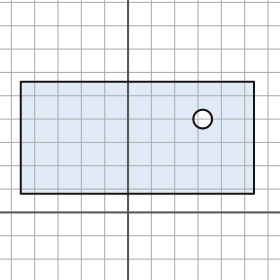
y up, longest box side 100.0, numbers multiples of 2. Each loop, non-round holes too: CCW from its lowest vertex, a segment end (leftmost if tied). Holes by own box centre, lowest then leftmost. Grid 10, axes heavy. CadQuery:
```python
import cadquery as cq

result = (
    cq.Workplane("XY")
    .moveTo(-46.0, 8.0)
    .lineTo(54.0, 8.0)
    .lineTo(54.0, 56.0)
    .lineTo(-46.0, 56.0)
    .close()
    .moveTo(32.0, 40.0)
    .circle(4.0)
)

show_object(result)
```